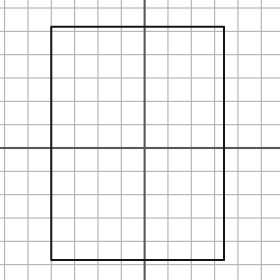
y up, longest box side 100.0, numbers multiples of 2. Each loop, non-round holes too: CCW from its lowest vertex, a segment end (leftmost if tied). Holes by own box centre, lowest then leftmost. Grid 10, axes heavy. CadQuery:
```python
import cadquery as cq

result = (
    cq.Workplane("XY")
    .moveTo(-40.0, -48.0)
    .lineTo(34.0, -48.0)
    .lineTo(34.0, 52.0)
    .lineTo(-40.0, 52.0)
    .close()
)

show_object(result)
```